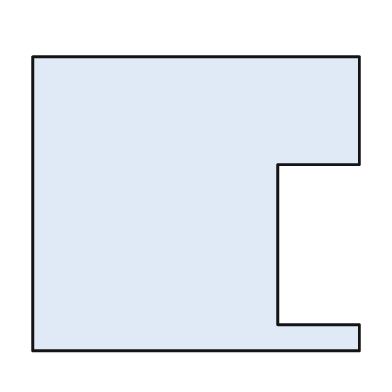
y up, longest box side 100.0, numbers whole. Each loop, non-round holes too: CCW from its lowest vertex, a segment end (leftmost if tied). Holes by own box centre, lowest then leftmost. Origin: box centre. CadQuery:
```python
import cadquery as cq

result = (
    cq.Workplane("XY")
    .moveTo(-50.0, -45.0)
    .lineTo(50.0, -45.0)
    .lineTo(50.0, -37.0)
    .lineTo(25.0, -37.0)
    .lineTo(25.0, 12.0)
    .lineTo(50.0, 12.0)
    .lineTo(50.0, 45.0)
    .lineTo(-50.0, 45.0)
    .close()
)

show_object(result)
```